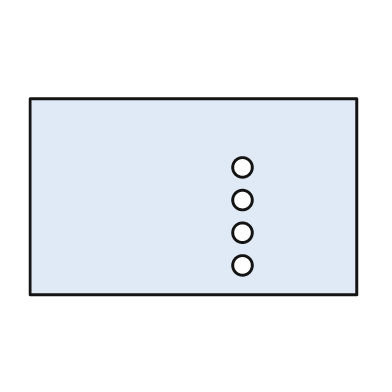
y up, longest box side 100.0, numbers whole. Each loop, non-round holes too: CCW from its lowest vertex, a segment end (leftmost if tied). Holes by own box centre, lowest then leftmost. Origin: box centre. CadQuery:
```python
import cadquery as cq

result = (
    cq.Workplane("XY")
    .moveTo(-50.0, -30.0)
    .lineTo(50.0, -30.0)
    .lineTo(50.0, 30.0)
    .lineTo(-50.0, 30.0)
    .close()
    .moveTo(15.0, -21.0)
    .circle(3.0)
    .moveTo(15.0, -11.0)
    .circle(3.0)
    .moveTo(15.0, -1.0)
    .circle(3.0)
    .moveTo(15.0, 9.0)
    .circle(3.0)
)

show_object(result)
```